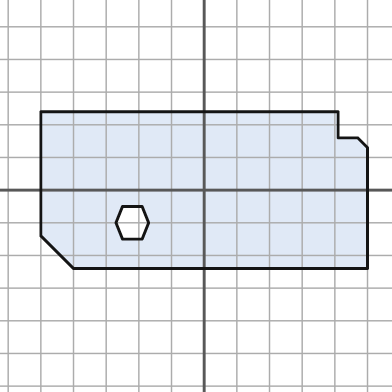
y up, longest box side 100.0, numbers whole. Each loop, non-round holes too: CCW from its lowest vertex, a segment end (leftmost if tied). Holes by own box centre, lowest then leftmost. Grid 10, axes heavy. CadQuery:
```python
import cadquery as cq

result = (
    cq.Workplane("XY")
    .moveTo(-40.0, -24.0)
    .lineTo(50.0, -24.0)
    .lineTo(50.0, 13.0)
    .lineTo(47.0, 16.0)
    .lineTo(41.0, 16.0)
    .lineTo(41.0, 24.0)
    .lineTo(-50.0, 24.0)
    .lineTo(-50.0, -14.0)
    .close()
    .moveTo(-25.0, -15.0)
    .lineTo(-19.0, -15.0)
    .lineTo(-17.0, -10.0)
    .lineTo(-19.0, -5.0)
    .lineTo(-25.0, -5.0)
    .lineTo(-27.0, -10.0)
    .close()
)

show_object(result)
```